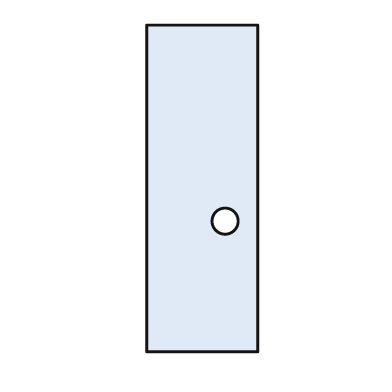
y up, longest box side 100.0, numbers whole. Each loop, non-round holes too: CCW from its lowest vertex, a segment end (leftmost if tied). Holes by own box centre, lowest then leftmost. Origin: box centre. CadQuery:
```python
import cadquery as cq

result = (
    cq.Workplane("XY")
    .moveTo(-17.0, -50.0)
    .lineTo(17.0, -50.0)
    .lineTo(17.0, 50.0)
    .lineTo(-17.0, 50.0)
    .close()
    .moveTo(7.0, -10.0)
    .circle(4.0)
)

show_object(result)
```